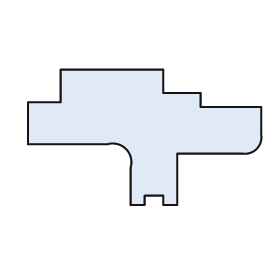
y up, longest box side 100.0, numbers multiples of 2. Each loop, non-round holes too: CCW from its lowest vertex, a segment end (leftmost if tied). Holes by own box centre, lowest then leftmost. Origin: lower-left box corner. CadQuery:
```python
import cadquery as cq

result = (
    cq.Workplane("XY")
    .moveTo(44.0, 0.0)
    .lineTo(50.0, 0.0)
    .lineTo(50.0, 4.0)
    .lineTo(58.0, 4.0)
    .lineTo(58.0, 0.0)
    .lineTo(64.0, 0.0)
    .lineTo(64.0, 22.0)
    .lineTo(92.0, 22.0)
    .threePointArc((98.0, 24.0), (100.0, 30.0))
    .lineTo(100.0, 42.0)
    .lineTo(74.0, 42.0)
    .lineTo(74.0, 48.0)
    .lineTo(58.0, 48.0)
    .lineTo(58.0, 58.0)
    .lineTo(14.0, 58.0)
    .lineTo(14.0, 44.0)
    .lineTo(0.0, 44.0)
    .lineTo(0.0, 26.0)
    .lineTo(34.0, 26.0)
    .threePointArc((42.0, 24.0), (44.0, 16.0))
    .close()
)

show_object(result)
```